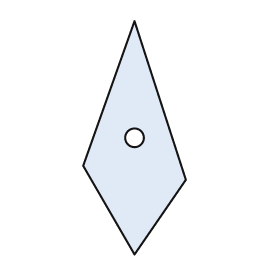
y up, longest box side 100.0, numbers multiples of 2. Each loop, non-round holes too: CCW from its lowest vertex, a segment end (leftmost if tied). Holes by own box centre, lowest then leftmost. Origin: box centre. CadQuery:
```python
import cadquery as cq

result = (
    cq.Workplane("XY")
    .moveTo(0.0, -50.0)
    .lineTo(22.0, -18.0)
    .lineTo(0.0, 50.0)
    .lineTo(-22.0, -12.0)
    .close()
    .moveTo(0.0, 0.0)
    .circle(4.0)
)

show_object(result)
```